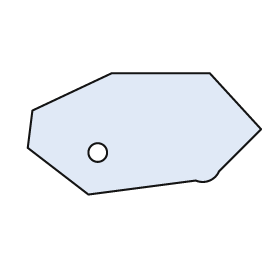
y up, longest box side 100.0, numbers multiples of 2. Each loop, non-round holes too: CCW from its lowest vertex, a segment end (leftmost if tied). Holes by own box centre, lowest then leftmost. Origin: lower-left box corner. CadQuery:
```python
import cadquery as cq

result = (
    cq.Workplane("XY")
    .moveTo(26.0, 0.0)
    .lineTo(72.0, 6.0)
    .threePointArc((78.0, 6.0), (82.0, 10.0))
    .lineTo(100.0, 28.0)
    .lineTo(78.0, 52.0)
    .lineTo(36.0, 52.0)
    .lineTo(2.0, 36.0)
    .lineTo(0.0, 20.0)
    .close()
    .moveTo(30.0, 18.0)
    .circle(4.0)
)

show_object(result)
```